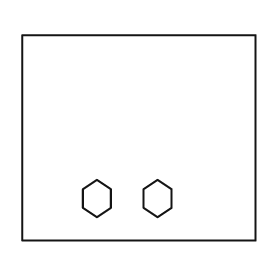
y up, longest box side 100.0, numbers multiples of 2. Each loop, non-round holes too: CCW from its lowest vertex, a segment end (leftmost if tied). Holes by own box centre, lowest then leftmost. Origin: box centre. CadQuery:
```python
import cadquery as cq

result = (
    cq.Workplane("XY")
    .moveTo(-50.0, -44.0)
    .lineTo(50.0, -44.0)
    .lineTo(50.0, 44.0)
    .lineTo(-50.0, 44.0)
    .close()
    .moveTo(-18.0, -34.0)
    .lineTo(-12.0, -30.0)
    .lineTo(-12.0, -22.0)
    .lineTo(-18.0, -18.0)
    .lineTo(-24.0, -22.0)
    .lineTo(-24.0, -30.0)
    .close()
    .moveTo(8.0, -34.0)
    .lineTo(14.0, -30.0)
    .lineTo(14.0, -22.0)
    .lineTo(8.0, -18.0)
    .lineTo(2.0, -22.0)
    .lineTo(2.0, -30.0)
    .close()
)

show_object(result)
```